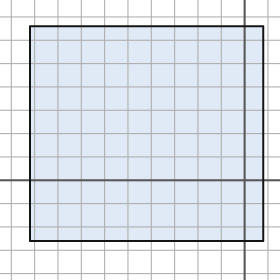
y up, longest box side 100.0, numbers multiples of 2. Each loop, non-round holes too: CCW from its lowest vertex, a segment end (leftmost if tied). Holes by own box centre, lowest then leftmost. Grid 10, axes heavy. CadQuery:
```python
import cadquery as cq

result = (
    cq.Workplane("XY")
    .moveTo(-92.0, -26.0)
    .lineTo(8.0, -26.0)
    .lineTo(8.0, 66.0)
    .lineTo(-92.0, 66.0)
    .close()
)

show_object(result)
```